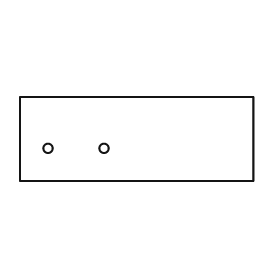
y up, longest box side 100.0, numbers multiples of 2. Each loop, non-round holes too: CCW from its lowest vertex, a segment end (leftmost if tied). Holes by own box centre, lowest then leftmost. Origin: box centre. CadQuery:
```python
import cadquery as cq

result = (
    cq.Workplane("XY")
    .moveTo(-50.0, -18.0)
    .lineTo(50.0, -18.0)
    .lineTo(50.0, 18.0)
    .lineTo(-50.0, 18.0)
    .close()
    .moveTo(-38.0, -4.0)
    .circle(2.0)
    .moveTo(-14.0, -4.0)
    .circle(2.0)
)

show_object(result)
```